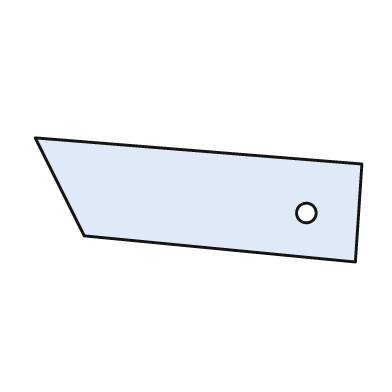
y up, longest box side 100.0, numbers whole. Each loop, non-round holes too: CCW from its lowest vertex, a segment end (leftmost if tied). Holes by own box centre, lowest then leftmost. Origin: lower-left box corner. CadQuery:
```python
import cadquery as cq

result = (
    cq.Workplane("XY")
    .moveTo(98.0, 0.0)
    .lineTo(100.0, 30.0)
    .lineTo(0.0, 38.0)
    .lineTo(15.0, 8.0)
    .close()
    .moveTo(83.0, 15.0)
    .circle(3.0)
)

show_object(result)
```